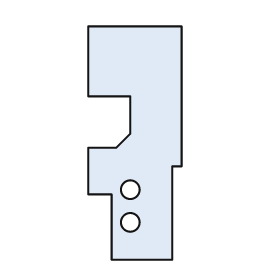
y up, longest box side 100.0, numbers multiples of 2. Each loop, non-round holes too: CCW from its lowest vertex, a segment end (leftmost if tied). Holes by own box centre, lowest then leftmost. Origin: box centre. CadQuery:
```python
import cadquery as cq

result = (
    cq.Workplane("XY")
    .moveTo(-10.0, -50.0)
    .lineTo(16.0, -50.0)
    .lineTo(16.0, -10.0)
    .lineTo(20.0, -10.0)
    .lineTo(20.0, 50.0)
    .lineTo(-20.0, 50.0)
    .lineTo(-20.0, 20.0)
    .lineTo(-2.0, 20.0)
    .lineTo(-2.0, 4.0)
    .lineTo(-8.0, -2.0)
    .lineTo(-20.0, -2.0)
    .lineTo(-20.0, -22.0)
    .lineTo(-10.0, -22.0)
    .close()
    .moveTo(-2.0, -34.0)
    .circle(4.0)
    .moveTo(-2.0, -20.0)
    .circle(4.0)
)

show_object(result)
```